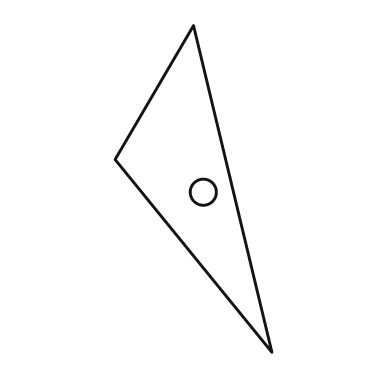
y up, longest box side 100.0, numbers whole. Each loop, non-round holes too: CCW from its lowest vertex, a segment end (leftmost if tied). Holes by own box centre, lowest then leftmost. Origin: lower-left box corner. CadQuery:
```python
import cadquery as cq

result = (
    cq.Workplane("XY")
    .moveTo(48.0, 0.0)
    .lineTo(24.0, 100.0)
    .lineTo(0.0, 59.0)
    .close()
    .moveTo(27.0, 49.0)
    .circle(4.0)
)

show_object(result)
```